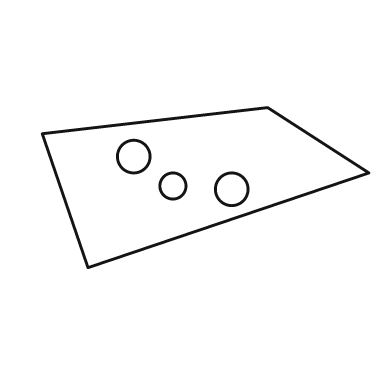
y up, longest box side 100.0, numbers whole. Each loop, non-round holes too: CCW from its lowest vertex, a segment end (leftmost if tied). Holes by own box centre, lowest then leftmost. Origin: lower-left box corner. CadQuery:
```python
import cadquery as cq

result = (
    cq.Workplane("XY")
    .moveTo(14.0, 0.0)
    .lineTo(100.0, 29.0)
    .lineTo(69.0, 49.0)
    .lineTo(0.0, 41.0)
    .close()
    .moveTo(58.0, 24.0)
    .circle(5.0)
    .moveTo(40.0, 25.0)
    .circle(4.0)
    .moveTo(28.0, 34.0)
    .circle(5.0)
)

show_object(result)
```